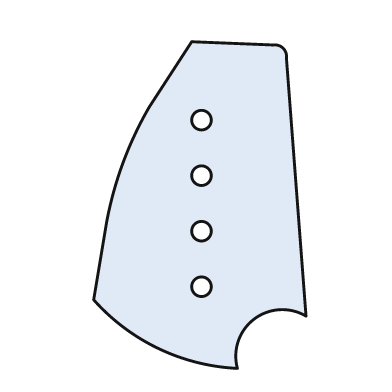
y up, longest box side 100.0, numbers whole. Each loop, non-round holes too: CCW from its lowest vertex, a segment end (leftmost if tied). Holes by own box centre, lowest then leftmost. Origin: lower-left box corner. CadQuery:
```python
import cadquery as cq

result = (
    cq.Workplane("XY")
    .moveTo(44.0, 0.0)
    .threePointArc((49.0, 15.0), (65.0, 16.0))
    .lineTo(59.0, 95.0)
    .threePointArc((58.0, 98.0), (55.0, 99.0))
    .lineTo(30.0, 100.0)
    .lineTo(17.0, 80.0)
    .threePointArc((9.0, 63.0), (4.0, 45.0))
    .lineTo(0.0, 21.0)
    .threePointArc((20.0, 6.0), (44.0, 0.0))
    .close()
    .moveTo(33.0, 25.0)
    .circle(3.0)
    .moveTo(33.0, 42.0)
    .circle(3.0)
    .moveTo(33.0, 59.0)
    .circle(3.0)
    .moveTo(33.0, 76.0)
    .circle(3.0)
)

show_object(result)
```